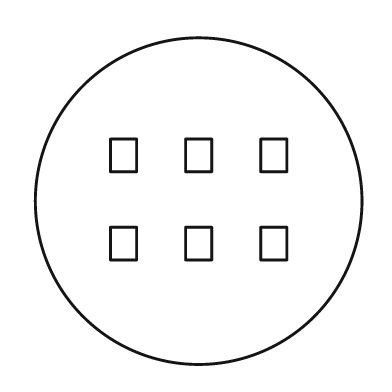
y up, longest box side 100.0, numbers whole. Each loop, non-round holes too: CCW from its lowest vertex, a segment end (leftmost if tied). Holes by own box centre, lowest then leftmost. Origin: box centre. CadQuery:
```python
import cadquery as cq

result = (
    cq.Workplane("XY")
    .moveTo(0.0, 0.0)
    .circle(50.0)
    .moveTo(-27.0, -18.0)
    .lineTo(-19.0, -18.0)
    .lineTo(-19.0, -8.0)
    .lineTo(-27.0, -8.0)
    .close()
    .moveTo(-4.0, -18.0)
    .lineTo(4.0, -18.0)
    .lineTo(4.0, -8.0)
    .lineTo(-4.0, -8.0)
    .close()
    .moveTo(19.0, -18.0)
    .lineTo(27.0, -18.0)
    .lineTo(27.0, -8.0)
    .lineTo(19.0, -8.0)
    .close()
    .moveTo(-27.0, 9.0)
    .lineTo(-19.0, 9.0)
    .lineTo(-19.0, 19.0)
    .lineTo(-27.0, 19.0)
    .close()
    .moveTo(-4.0, 9.0)
    .lineTo(4.0, 9.0)
    .lineTo(4.0, 19.0)
    .lineTo(-4.0, 19.0)
    .close()
    .moveTo(19.0, 9.0)
    .lineTo(27.0, 9.0)
    .lineTo(27.0, 19.0)
    .lineTo(19.0, 19.0)
    .close()
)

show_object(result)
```